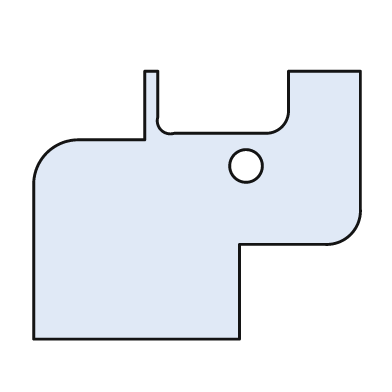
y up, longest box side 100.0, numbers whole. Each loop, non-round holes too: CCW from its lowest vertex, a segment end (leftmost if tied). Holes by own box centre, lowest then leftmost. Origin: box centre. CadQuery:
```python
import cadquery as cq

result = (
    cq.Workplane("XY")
    .moveTo(-50.0, -41.0)
    .lineTo(13.0, -41.0)
    .lineTo(13.0, -12.0)
    .lineTo(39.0, -12.0)
    .threePointArc((47.0, -9.0), (50.0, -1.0))
    .lineTo(50.0, 41.0)
    .lineTo(28.0, 41.0)
    .lineTo(28.0, 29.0)
    .threePointArc((26.0, 24.0), (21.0, 22.0))
    .lineTo(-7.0, 22.0)
    .threePointArc((-11.0, 23.0), (-12.0, 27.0))
    .lineTo(-12.0, 41.0)
    .lineTo(-16.0, 41.0)
    .lineTo(-16.0, 20.0)
    .lineTo(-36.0, 20.0)
    .threePointArc((-46.0, 16.0), (-50.0, 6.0))
    .close()
    .moveTo(15.0, 12.0)
    .circle(5.0)
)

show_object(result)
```